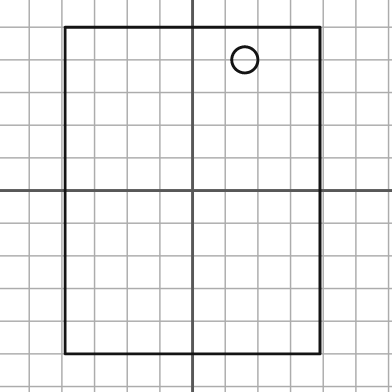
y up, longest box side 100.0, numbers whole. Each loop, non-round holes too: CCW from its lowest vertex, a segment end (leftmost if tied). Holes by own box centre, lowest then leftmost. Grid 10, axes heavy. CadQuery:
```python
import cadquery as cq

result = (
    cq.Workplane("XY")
    .moveTo(-39.0, -50.0)
    .lineTo(39.0, -50.0)
    .lineTo(39.0, 50.0)
    .lineTo(-39.0, 50.0)
    .close()
    .moveTo(16.0, 40.0)
    .circle(4.0)
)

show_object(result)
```